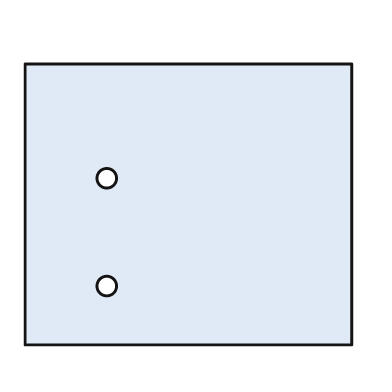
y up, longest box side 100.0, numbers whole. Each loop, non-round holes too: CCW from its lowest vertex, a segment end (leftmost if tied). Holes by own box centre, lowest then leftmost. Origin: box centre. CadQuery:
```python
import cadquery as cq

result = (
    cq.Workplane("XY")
    .moveTo(-50.0, -43.0)
    .lineTo(50.0, -43.0)
    .lineTo(50.0, 43.0)
    .lineTo(-50.0, 43.0)
    .close()
    .moveTo(-25.0, -25.0)
    .circle(3.0)
    .moveTo(-25.0, 8.0)
    .circle(3.0)
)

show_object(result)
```